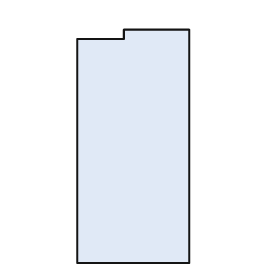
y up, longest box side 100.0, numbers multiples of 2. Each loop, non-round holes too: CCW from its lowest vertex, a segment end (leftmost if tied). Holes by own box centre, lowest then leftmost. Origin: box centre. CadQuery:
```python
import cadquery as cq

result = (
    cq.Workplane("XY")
    .moveTo(-24.0, -50.0)
    .lineTo(24.0, -50.0)
    .lineTo(24.0, 50.0)
    .lineTo(-4.0, 50.0)
    .lineTo(-4.0, 46.0)
    .lineTo(-24.0, 46.0)
    .close()
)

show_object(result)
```